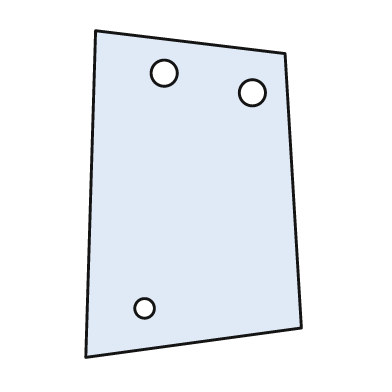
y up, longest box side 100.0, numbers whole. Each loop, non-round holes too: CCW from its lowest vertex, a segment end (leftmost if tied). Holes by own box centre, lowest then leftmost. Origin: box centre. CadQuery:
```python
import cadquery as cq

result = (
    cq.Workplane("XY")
    .moveTo(-33.0, -50.0)
    .lineTo(33.0, -41.0)
    .lineTo(28.0, 43.0)
    .lineTo(-30.0, 50.0)
    .close()
    .moveTo(-15.0, -35.0)
    .circle(3.0)
    .moveTo(18.0, 31.0)
    .circle(4.0)
    .moveTo(-9.0, 37.0)
    .circle(4.0)
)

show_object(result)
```